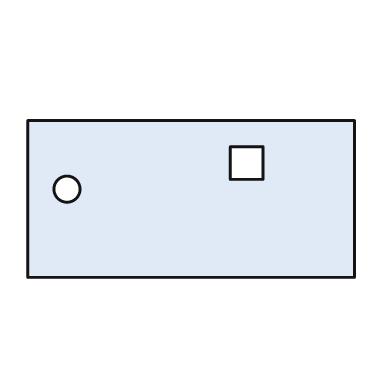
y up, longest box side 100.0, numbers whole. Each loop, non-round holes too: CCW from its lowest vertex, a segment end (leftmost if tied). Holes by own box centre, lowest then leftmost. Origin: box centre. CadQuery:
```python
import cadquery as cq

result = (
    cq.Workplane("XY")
    .moveTo(-50.0, -24.0)
    .lineTo(50.0, -24.0)
    .lineTo(50.0, 24.0)
    .lineTo(-50.0, 24.0)
    .close()
    .moveTo(-38.0, 3.0)
    .circle(4.0)
    .moveTo(12.0, 6.0)
    .lineTo(22.0, 6.0)
    .lineTo(22.0, 16.0)
    .lineTo(12.0, 16.0)
    .close()
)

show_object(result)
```